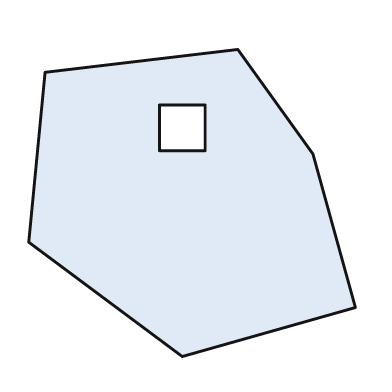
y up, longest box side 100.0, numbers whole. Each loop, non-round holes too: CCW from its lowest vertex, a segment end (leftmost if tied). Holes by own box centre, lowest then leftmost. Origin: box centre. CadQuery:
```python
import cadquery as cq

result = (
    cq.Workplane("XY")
    .moveTo(-3.0, -47.0)
    .lineTo(50.0, -32.0)
    .lineTo(37.0, 15.0)
    .lineTo(14.0, 47.0)
    .lineTo(-45.0, 40.0)
    .lineTo(-50.0, -12.0)
    .close()
    .moveTo(-10.0, 16.0)
    .lineTo(4.0, 16.0)
    .lineTo(4.0, 30.0)
    .lineTo(-10.0, 30.0)
    .close()
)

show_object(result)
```